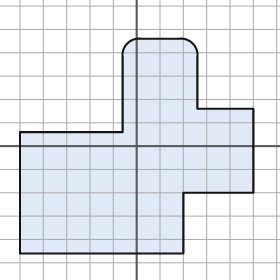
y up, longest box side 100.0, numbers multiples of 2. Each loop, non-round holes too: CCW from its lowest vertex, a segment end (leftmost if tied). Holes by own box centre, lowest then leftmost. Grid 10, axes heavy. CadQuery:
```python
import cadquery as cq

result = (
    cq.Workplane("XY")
    .moveTo(-50.0, -46.0)
    .lineTo(20.0, -46.0)
    .lineTo(20.0, -20.0)
    .lineTo(50.0, -20.0)
    .lineTo(50.0, 16.0)
    .lineTo(26.0, 16.0)
    .lineTo(26.0, 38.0)
    .threePointArc((24.0, 44.0), (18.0, 46.0))
    .lineTo(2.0, 46.0)
    .threePointArc((-4.0, 44.0), (-6.0, 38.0))
    .lineTo(-6.0, 6.0)
    .lineTo(-50.0, 6.0)
    .close()
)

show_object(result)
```